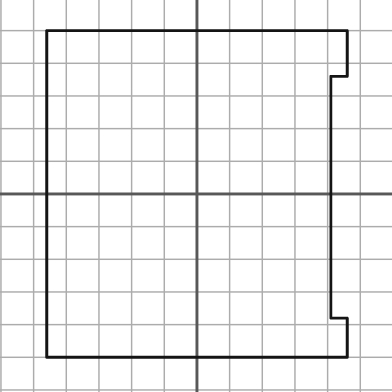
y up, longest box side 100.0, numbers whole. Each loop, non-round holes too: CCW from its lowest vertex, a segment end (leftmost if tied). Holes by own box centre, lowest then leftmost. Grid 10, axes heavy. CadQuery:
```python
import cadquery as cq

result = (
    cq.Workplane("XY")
    .moveTo(-46.0, -50.0)
    .lineTo(46.0, -50.0)
    .lineTo(46.0, -38.0)
    .lineTo(41.0, -38.0)
    .lineTo(41.0, 36.0)
    .lineTo(46.0, 36.0)
    .lineTo(46.0, 50.0)
    .lineTo(-46.0, 50.0)
    .close()
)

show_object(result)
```